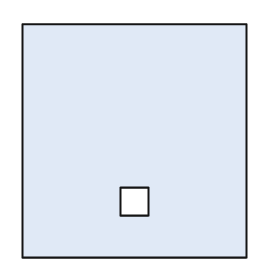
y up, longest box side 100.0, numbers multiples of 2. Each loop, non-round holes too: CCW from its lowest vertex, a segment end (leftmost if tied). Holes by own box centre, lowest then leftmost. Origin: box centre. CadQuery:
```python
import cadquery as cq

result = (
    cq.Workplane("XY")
    .moveTo(-48.0, -50.0)
    .lineTo(48.0, -50.0)
    .lineTo(48.0, 50.0)
    .lineTo(-48.0, 50.0)
    .close()
    .moveTo(-6.0, -32.0)
    .lineTo(6.0, -32.0)
    .lineTo(6.0, -20.0)
    .lineTo(-6.0, -20.0)
    .close()
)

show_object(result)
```